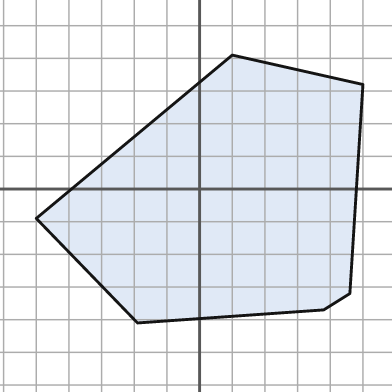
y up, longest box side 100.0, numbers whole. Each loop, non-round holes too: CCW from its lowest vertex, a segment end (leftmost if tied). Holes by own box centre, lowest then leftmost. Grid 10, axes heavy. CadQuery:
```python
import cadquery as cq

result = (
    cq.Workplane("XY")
    .moveTo(-19.0, -41.0)
    .lineTo(38.0, -37.0)
    .lineTo(46.0, -32.0)
    .lineTo(50.0, 32.0)
    .lineTo(10.0, 41.0)
    .lineTo(-50.0, -9.0)
    .close()
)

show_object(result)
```